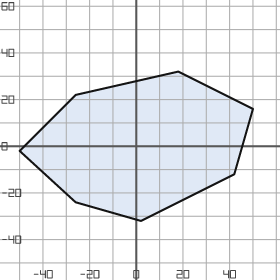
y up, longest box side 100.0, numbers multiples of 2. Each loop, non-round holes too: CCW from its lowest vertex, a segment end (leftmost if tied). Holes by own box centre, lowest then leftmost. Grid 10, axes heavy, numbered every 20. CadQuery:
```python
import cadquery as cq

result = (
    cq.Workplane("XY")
    .moveTo(2.0, -32.0)
    .lineTo(42.0, -12.0)
    .lineTo(50.0, 16.0)
    .lineTo(18.0, 32.0)
    .lineTo(-26.0, 22.0)
    .lineTo(-50.0, -2.0)
    .lineTo(-26.0, -24.0)
    .close()
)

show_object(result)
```